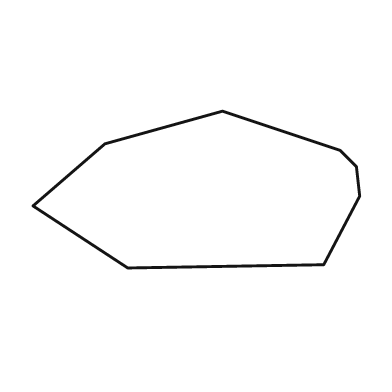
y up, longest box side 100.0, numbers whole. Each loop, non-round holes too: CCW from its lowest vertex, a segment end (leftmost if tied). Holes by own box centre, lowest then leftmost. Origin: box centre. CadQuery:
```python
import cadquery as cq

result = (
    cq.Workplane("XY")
    .moveTo(-21.0, -24.0)
    .lineTo(39.0, -23.0)
    .lineTo(50.0, -2.0)
    .lineTo(49.0, 7.0)
    .lineTo(44.0, 12.0)
    .lineTo(8.0, 24.0)
    .lineTo(-28.0, 14.0)
    .lineTo(-50.0, -5.0)
    .close()
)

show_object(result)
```